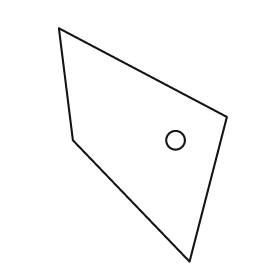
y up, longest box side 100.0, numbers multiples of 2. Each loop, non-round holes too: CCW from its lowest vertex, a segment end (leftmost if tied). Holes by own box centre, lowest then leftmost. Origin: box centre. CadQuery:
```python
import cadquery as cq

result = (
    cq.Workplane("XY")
    .moveTo(20.0, -50.0)
    .lineTo(36.0, 12.0)
    .lineTo(-36.0, 50.0)
    .lineTo(-30.0, 2.0)
    .close()
    .moveTo(14.0, 2.0)
    .circle(4.0)
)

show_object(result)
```